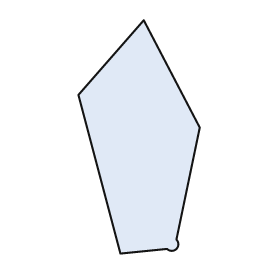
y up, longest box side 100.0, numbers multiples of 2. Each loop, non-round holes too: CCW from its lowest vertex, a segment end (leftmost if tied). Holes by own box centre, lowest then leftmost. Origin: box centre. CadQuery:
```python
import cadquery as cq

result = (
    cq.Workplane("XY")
    .moveTo(-8.0, -50.0)
    .lineTo(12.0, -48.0)
    .threePointArc((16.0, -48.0), (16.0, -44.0))
    .lineTo(26.0, 4.0)
    .lineTo(2.0, 50.0)
    .lineTo(-26.0, 18.0)
    .close()
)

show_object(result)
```